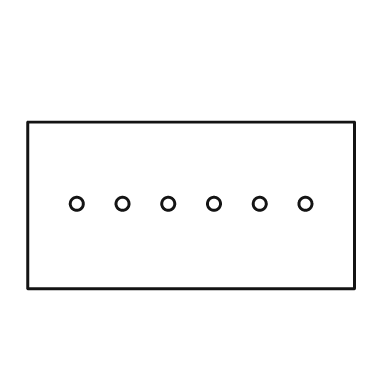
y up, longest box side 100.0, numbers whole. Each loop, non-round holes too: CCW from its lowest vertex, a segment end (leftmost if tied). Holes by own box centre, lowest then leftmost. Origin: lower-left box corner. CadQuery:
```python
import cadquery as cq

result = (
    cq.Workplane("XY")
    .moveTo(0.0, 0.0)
    .lineTo(100.0, 0.0)
    .lineTo(100.0, 51.0)
    .lineTo(0.0, 51.0)
    .close()
    .moveTo(15.0, 26.0)
    .circle(2.0)
    .moveTo(29.0, 26.0)
    .circle(2.0)
    .moveTo(43.0, 26.0)
    .circle(2.0)
    .moveTo(57.0, 26.0)
    .circle(2.0)
    .moveTo(71.0, 26.0)
    .circle(2.0)
    .moveTo(85.0, 26.0)
    .circle(2.0)
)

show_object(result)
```